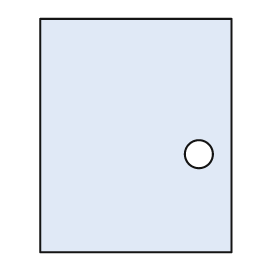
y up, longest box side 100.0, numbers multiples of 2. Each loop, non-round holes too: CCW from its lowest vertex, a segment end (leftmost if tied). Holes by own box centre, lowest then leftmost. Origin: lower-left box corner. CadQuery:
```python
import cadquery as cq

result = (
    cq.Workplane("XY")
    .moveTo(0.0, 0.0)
    .lineTo(82.0, 0.0)
    .lineTo(82.0, 100.0)
    .lineTo(0.0, 100.0)
    .close()
    .moveTo(68.0, 42.0)
    .circle(6.0)
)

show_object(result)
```